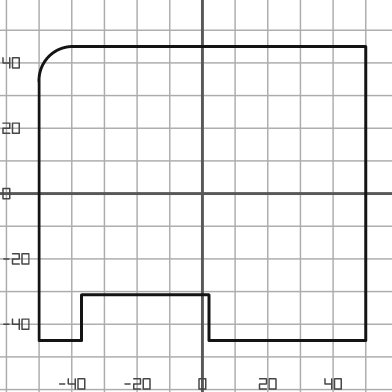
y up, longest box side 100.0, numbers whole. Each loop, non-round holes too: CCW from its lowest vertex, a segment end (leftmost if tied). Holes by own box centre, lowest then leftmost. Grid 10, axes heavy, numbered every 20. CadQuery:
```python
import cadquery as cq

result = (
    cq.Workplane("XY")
    .moveTo(-50.0, -45.0)
    .lineTo(-37.0, -45.0)
    .lineTo(-37.0, -31.0)
    .lineTo(2.0, -31.0)
    .lineTo(2.0, -45.0)
    .lineTo(50.0, -45.0)
    .lineTo(50.0, 45.0)
    .lineTo(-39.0, 45.0)
    .threePointArc((-47.0, 42.0), (-50.0, 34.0))
    .close()
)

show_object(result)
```